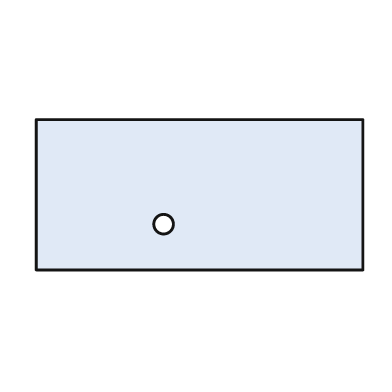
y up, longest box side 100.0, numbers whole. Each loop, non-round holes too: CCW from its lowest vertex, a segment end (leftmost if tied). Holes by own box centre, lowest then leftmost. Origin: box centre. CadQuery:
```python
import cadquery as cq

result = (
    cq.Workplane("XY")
    .moveTo(-50.0, -23.0)
    .lineTo(50.0, -23.0)
    .lineTo(50.0, 23.0)
    .lineTo(-50.0, 23.0)
    .close()
    .moveTo(-11.0, -9.0)
    .circle(3.0)
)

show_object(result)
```